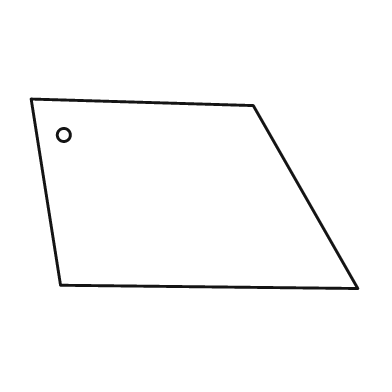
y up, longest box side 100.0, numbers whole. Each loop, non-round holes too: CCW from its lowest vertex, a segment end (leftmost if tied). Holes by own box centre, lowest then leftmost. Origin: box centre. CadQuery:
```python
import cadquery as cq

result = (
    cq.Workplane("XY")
    .moveTo(50.0, -29.0)
    .lineTo(18.0, 27.0)
    .lineTo(-50.0, 29.0)
    .lineTo(-41.0, -28.0)
    .close()
    .moveTo(-40.0, 18.0)
    .circle(2.0)
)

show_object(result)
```